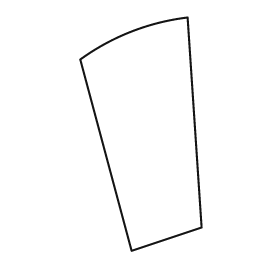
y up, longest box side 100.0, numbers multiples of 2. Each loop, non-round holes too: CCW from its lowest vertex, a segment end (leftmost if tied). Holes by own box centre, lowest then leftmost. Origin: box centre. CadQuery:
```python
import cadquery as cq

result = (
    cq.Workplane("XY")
    .moveTo(-4.0, -50.0)
    .lineTo(26.0, -40.0)
    .lineTo(20.0, 50.0)
    .threePointArc((-4.0, 44.0), (-26.0, 32.0))
    .close()
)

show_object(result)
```